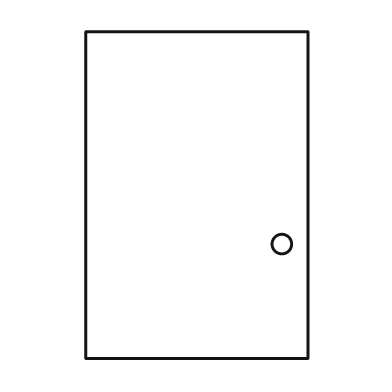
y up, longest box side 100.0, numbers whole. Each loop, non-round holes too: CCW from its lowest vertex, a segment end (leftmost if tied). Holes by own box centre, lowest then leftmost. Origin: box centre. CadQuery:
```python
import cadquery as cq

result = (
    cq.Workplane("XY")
    .moveTo(-34.0, -50.0)
    .lineTo(34.0, -50.0)
    .lineTo(34.0, 50.0)
    .lineTo(-34.0, 50.0)
    .close()
    .moveTo(26.0, -15.0)
    .circle(3.0)
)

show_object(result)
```